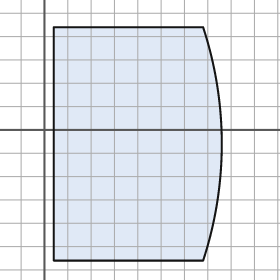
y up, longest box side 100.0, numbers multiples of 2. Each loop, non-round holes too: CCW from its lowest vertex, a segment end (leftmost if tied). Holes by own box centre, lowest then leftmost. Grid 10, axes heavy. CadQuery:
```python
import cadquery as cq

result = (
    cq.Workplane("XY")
    .moveTo(4.0, -56.0)
    .lineTo(68.0, -56.0)
    .threePointArc((76.0, -6.0), (68.0, 44.0))
    .lineTo(4.0, 44.0)
    .close()
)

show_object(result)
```